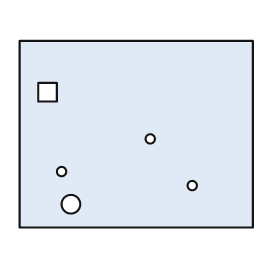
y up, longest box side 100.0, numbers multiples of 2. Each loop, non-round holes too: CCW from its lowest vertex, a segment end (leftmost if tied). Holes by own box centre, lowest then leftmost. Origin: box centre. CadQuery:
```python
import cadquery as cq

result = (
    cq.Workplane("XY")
    .moveTo(-50.0, -40.0)
    .lineTo(50.0, -40.0)
    .lineTo(50.0, 40.0)
    .lineTo(-50.0, 40.0)
    .close()
    .moveTo(-28.0, -30.0)
    .circle(4.0)
    .moveTo(24.0, -22.0)
    .circle(2.0)
    .moveTo(-32.0, -16.0)
    .circle(2.0)
    .moveTo(6.0, -2.0)
    .circle(2.0)
    .moveTo(-42.0, 14.0)
    .lineTo(-34.0, 14.0)
    .lineTo(-34.0, 22.0)
    .lineTo(-42.0, 22.0)
    .close()
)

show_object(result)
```